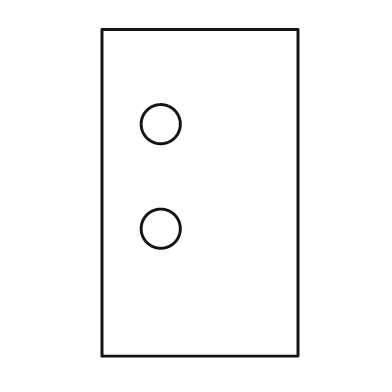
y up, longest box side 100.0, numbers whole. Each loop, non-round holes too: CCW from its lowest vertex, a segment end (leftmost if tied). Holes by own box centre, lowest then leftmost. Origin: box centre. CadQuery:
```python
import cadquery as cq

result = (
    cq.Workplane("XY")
    .moveTo(-30.0, -50.0)
    .lineTo(30.0, -50.0)
    .lineTo(30.0, 50.0)
    .lineTo(-30.0, 50.0)
    .close()
    .moveTo(-12.0, -11.0)
    .circle(6.0)
    .moveTo(-12.0, 21.0)
    .circle(6.0)
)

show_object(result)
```